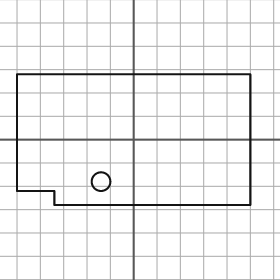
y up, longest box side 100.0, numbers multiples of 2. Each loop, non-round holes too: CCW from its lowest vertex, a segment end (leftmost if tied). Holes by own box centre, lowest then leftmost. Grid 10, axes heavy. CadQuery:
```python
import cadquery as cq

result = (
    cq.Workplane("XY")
    .moveTo(-34.0, -28.0)
    .lineTo(50.0, -28.0)
    .lineTo(50.0, 28.0)
    .lineTo(-50.0, 28.0)
    .lineTo(-50.0, -22.0)
    .lineTo(-34.0, -22.0)
    .close()
    .moveTo(-14.0, -18.0)
    .circle(4.0)
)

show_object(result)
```